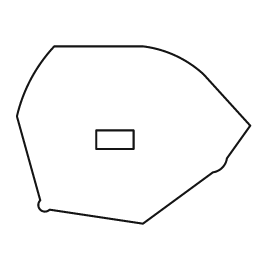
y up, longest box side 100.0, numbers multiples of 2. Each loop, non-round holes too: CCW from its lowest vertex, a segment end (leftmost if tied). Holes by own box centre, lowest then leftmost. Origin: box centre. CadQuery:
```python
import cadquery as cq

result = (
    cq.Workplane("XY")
    .moveTo(4.0, -38.0)
    .lineTo(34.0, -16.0)
    .threePointArc((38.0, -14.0), (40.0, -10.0))
    .lineTo(50.0, 4.0)
    .lineTo(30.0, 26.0)
    .threePointArc((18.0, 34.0), (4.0, 38.0))
    .lineTo(-34.0, 38.0)
    .threePointArc((-44.0, 24.0), (-50.0, 8.0))
    .lineTo(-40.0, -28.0)
    .threePointArc((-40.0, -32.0), (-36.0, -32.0))
    .close()
    .moveTo(-16.0, -6.0)
    .lineTo(0.0, -6.0)
    .lineTo(0.0, 2.0)
    .lineTo(-16.0, 2.0)
    .close()
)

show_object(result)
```